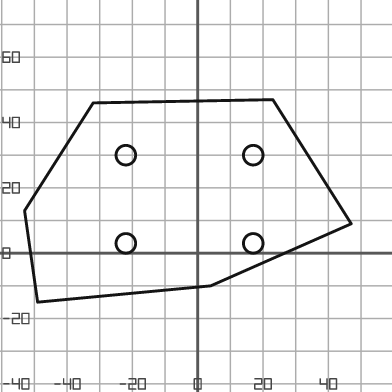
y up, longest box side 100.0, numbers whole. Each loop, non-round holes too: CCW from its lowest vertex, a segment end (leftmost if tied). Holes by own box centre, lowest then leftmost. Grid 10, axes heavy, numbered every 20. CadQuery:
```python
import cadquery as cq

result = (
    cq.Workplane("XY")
    .moveTo(-49.0, -15.0)
    .lineTo(4.0, -10.0)
    .lineTo(47.0, 9.0)
    .lineTo(23.0, 47.0)
    .lineTo(-32.0, 46.0)
    .lineTo(-53.0, 13.0)
    .close()
    .moveTo(-22.0, 3.0)
    .circle(3.0)
    .moveTo(17.0, 3.0)
    .circle(3.0)
    .moveTo(-22.0, 30.0)
    .circle(3.0)
    .moveTo(17.0, 30.0)
    .circle(3.0)
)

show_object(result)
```